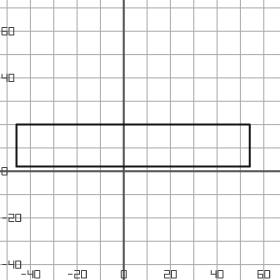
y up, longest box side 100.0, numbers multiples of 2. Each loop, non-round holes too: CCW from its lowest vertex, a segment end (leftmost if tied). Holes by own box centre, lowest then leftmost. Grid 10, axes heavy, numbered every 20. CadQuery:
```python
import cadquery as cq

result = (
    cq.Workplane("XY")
    .moveTo(-46.0, 2.0)
    .lineTo(54.0, 2.0)
    .lineTo(54.0, 20.0)
    .lineTo(-46.0, 20.0)
    .close()
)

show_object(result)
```